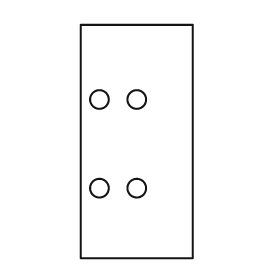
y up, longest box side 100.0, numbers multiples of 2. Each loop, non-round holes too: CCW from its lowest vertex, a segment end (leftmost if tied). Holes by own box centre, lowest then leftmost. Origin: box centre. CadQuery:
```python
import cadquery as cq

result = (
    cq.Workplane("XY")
    .moveTo(-24.0, -50.0)
    .lineTo(24.0, -50.0)
    .lineTo(24.0, 50.0)
    .lineTo(-24.0, 50.0)
    .close()
    .moveTo(-16.0, -20.0)
    .circle(4.0)
    .moveTo(0.0, -20.0)
    .circle(4.0)
    .moveTo(-16.0, 18.0)
    .circle(4.0)
    .moveTo(0.0, 18.0)
    .circle(4.0)
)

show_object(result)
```